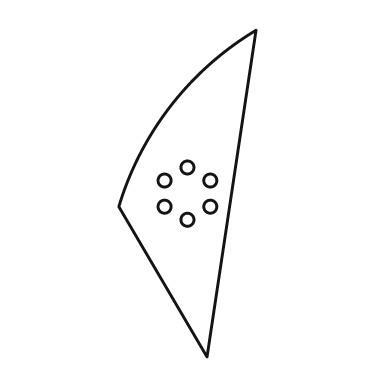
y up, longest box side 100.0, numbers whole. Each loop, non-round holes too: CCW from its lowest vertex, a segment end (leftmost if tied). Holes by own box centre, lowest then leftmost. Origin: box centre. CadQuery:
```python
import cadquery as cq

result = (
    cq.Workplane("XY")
    .moveTo(6.0, -50.0)
    .lineTo(21.0, 50.0)
    .threePointArc((-5.0, 27.0), (-21.0, -4.0))
    .close()
    .moveTo(0.0, -8.0)
    .circle(2.0)
    .moveTo(-7.0, -4.0)
    .circle(2.0)
    .moveTo(7.0, -4.0)
    .circle(2.0)
    .moveTo(-7.0, 4.0)
    .circle(2.0)
    .moveTo(7.0, 4.0)
    .circle(2.0)
    .moveTo(0.0, 8.0)
    .circle(2.0)
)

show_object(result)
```